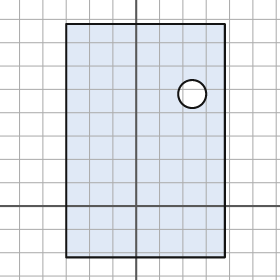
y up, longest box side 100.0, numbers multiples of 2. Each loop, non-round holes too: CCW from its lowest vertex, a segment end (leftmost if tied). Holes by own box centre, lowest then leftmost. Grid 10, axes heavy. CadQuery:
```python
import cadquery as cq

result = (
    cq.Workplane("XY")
    .moveTo(-30.0, -22.0)
    .lineTo(38.0, -22.0)
    .lineTo(38.0, 78.0)
    .lineTo(-30.0, 78.0)
    .close()
    .moveTo(24.0, 48.0)
    .circle(6.0)
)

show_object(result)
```